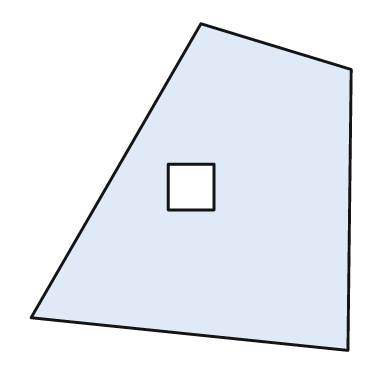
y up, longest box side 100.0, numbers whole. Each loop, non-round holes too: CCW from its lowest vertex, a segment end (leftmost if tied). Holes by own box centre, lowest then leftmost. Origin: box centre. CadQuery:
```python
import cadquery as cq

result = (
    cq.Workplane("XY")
    .moveTo(48.0, -50.0)
    .lineTo(49.0, 36.0)
    .lineTo(3.0, 50.0)
    .lineTo(-49.0, -40.0)
    .close()
    .moveTo(-7.0, -7.0)
    .lineTo(7.0, -7.0)
    .lineTo(7.0, 7.0)
    .lineTo(-7.0, 7.0)
    .close()
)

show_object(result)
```